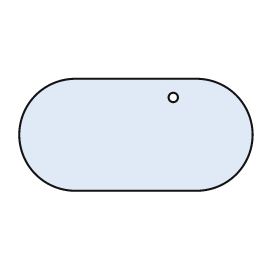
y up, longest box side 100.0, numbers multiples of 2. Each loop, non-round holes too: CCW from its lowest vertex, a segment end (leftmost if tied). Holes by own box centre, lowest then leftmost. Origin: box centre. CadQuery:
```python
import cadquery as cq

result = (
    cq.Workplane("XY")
    .moveTo(-26.0, -24.0)
    .lineTo(26.0, -24.0)
    .threePointArc((50.0, 0.0), (26.0, 24.0))
    .lineTo(-26.0, 24.0)
    .threePointArc((-50.0, 0.0), (-26.0, -24.0))
    .close()
    .moveTo(16.0, 16.0)
    .circle(2.0)
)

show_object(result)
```